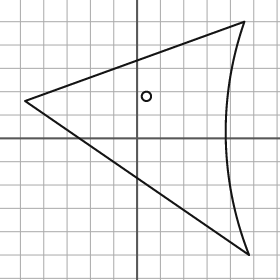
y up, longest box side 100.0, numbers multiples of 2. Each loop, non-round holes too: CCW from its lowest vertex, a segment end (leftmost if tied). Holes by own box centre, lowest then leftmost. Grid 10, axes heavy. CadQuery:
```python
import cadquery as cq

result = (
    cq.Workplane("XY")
    .moveTo(48.0, -50.0)
    .threePointArc((38.0, 0.0), (46.0, 50.0))
    .lineTo(-48.0, 16.0)
    .close()
    .moveTo(4.0, 18.0)
    .circle(2.0)
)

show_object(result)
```